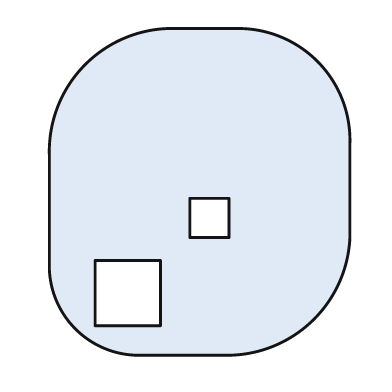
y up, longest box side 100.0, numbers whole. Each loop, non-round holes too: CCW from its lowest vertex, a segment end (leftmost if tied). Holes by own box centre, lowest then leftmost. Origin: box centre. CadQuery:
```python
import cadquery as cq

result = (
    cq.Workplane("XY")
    .moveTo(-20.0, -50.0)
    .lineTo(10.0, -50.0)
    .threePointArc((35.0, -39.0), (46.0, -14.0))
    .lineTo(46.0, 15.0)
    .threePointArc((36.0, 40.0), (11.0, 50.0))
    .lineTo(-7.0, 50.0)
    .threePointArc((-35.0, 39.0), (-46.0, 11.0))
    .lineTo(-46.0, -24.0)
    .threePointArc((-38.0, -42.0), (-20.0, -50.0))
    .close()
    .moveTo(-32.0, -41.0)
    .lineTo(-12.0, -41.0)
    .lineTo(-12.0, -21.0)
    .lineTo(-32.0, -21.0)
    .close()
    .moveTo(-3.0, -14.0)
    .lineTo(9.0, -14.0)
    .lineTo(9.0, -2.0)
    .lineTo(-3.0, -2.0)
    .close()
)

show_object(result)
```